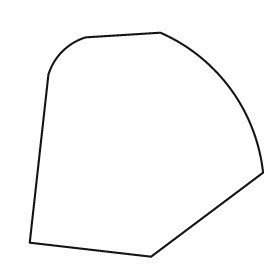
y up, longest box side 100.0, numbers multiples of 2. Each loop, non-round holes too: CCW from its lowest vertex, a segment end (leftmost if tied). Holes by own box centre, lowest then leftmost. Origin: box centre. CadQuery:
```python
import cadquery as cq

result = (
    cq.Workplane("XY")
    .moveTo(2.0, -48.0)
    .lineTo(50.0, -12.0)
    .threePointArc((36.0, 24.0), (6.0, 48.0))
    .lineTo(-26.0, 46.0)
    .threePointArc((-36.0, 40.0), (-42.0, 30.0))
    .lineTo(-50.0, -42.0)
    .close()
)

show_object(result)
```